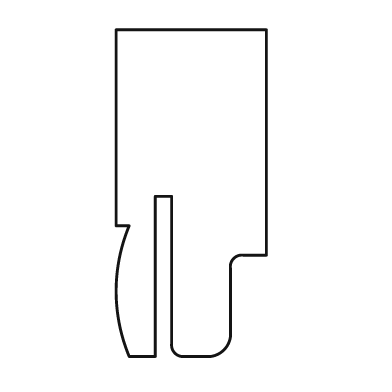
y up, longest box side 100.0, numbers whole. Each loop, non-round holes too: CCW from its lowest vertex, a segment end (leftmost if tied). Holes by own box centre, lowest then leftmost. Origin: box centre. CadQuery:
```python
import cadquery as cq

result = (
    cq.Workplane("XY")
    .moveTo(-19.0, -50.0)
    .lineTo(-11.0, -50.0)
    .lineTo(-11.0, -1.0)
    .lineTo(-6.0, -1.0)
    .lineTo(-6.0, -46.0)
    .threePointArc((-5.0, -49.0), (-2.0, -50.0))
    .lineTo(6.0, -50.0)
    .threePointArc((10.0, -48.0), (12.0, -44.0))
    .lineTo(12.0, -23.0)
    .threePointArc((13.0, -20.0), (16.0, -19.0))
    .lineTo(23.0, -19.0)
    .lineTo(23.0, 50.0)
    .lineTo(-23.0, 50.0)
    .lineTo(-23.0, -10.0)
    .lineTo(-19.0, -10.0)
    .threePointArc((-23.0, -30.0), (-19.0, -50.0))
    .close()
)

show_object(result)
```